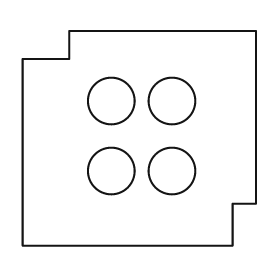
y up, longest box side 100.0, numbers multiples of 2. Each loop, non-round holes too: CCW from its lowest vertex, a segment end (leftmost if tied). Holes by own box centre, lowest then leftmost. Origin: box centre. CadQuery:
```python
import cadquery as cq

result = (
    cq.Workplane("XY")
    .moveTo(-50.0, -46.0)
    .lineTo(40.0, -46.0)
    .lineTo(40.0, -28.0)
    .lineTo(50.0, -28.0)
    .lineTo(50.0, 46.0)
    .lineTo(-30.0, 46.0)
    .lineTo(-30.0, 34.0)
    .lineTo(-50.0, 34.0)
    .close()
    .moveTo(-12.0, -14.0)
    .circle(10.0)
    .moveTo(14.0, -14.0)
    .circle(10.0)
    .moveTo(-12.0, 16.0)
    .circle(10.0)
    .moveTo(14.0, 16.0)
    .circle(10.0)
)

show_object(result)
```